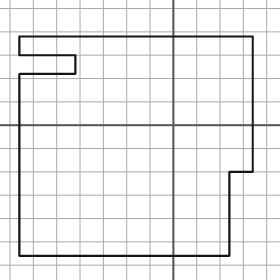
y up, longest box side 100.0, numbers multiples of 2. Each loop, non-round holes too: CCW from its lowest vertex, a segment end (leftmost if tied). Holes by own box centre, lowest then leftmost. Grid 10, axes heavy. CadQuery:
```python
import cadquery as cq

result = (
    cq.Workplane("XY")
    .moveTo(-66.0, -56.0)
    .lineTo(24.0, -56.0)
    .lineTo(24.0, -20.0)
    .lineTo(34.0, -20.0)
    .lineTo(34.0, 38.0)
    .lineTo(-66.0, 38.0)
    .lineTo(-66.0, 30.0)
    .lineTo(-42.0, 30.0)
    .lineTo(-42.0, 22.0)
    .lineTo(-66.0, 22.0)
    .close()
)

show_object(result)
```